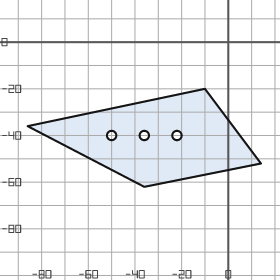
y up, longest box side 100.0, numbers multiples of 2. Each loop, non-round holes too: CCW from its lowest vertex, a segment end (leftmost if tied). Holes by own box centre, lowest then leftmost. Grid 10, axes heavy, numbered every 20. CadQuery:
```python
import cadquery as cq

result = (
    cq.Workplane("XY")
    .moveTo(-36.0, -62.0)
    .lineTo(14.0, -52.0)
    .lineTo(-10.0, -20.0)
    .lineTo(-86.0, -36.0)
    .close()
    .moveTo(-50.0, -40.0)
    .circle(2.0)
    .moveTo(-36.0, -40.0)
    .circle(2.0)
    .moveTo(-22.0, -40.0)
    .circle(2.0)
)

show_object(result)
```